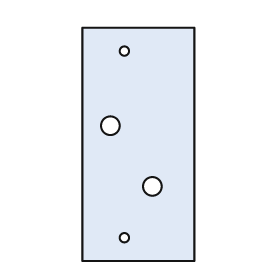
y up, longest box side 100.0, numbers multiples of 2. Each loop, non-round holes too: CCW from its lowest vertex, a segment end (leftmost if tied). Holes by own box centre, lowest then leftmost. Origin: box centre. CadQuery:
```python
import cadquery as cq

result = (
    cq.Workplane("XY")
    .moveTo(-24.0, -50.0)
    .lineTo(24.0, -50.0)
    .lineTo(24.0, 50.0)
    .lineTo(-24.0, 50.0)
    .close()
    .moveTo(-6.0, -40.0)
    .circle(2.0)
    .moveTo(6.0, -18.0)
    .circle(4.0)
    .moveTo(-12.0, 8.0)
    .circle(4.0)
    .moveTo(-6.0, 40.0)
    .circle(2.0)
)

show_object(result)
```